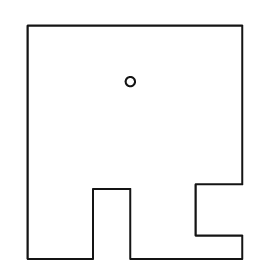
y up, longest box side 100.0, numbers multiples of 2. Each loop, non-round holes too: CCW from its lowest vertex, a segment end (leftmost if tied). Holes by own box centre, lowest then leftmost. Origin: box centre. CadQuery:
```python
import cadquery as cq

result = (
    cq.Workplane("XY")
    .moveTo(-46.0, -50.0)
    .lineTo(-18.0, -50.0)
    .lineTo(-18.0, -20.0)
    .lineTo(-2.0, -20.0)
    .lineTo(-2.0, -50.0)
    .lineTo(46.0, -50.0)
    .lineTo(46.0, -40.0)
    .lineTo(26.0, -40.0)
    .lineTo(26.0, -18.0)
    .lineTo(46.0, -18.0)
    .lineTo(46.0, 50.0)
    .lineTo(-46.0, 50.0)
    .close()
    .moveTo(-2.0, 26.0)
    .circle(2.0)
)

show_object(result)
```